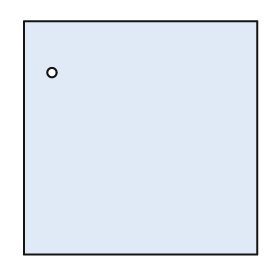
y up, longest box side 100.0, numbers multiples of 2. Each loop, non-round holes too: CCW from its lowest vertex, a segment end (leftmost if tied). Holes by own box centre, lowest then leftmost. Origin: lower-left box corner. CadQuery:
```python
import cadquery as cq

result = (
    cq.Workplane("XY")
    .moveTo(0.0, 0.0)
    .lineTo(100.0, 0.0)
    .lineTo(100.0, 100.0)
    .lineTo(0.0, 100.0)
    .close()
    .moveTo(12.0, 78.0)
    .circle(2.0)
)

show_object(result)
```